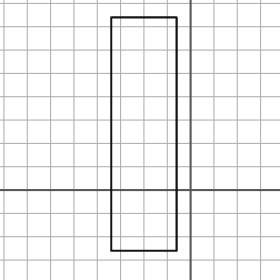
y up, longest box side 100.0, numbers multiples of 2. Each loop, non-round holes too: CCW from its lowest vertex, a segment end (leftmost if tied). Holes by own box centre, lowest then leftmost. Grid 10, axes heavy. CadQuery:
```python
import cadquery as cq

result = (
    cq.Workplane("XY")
    .moveTo(-34.0, -26.0)
    .lineTo(-6.0, -26.0)
    .lineTo(-6.0, 74.0)
    .lineTo(-34.0, 74.0)
    .close()
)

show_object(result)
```